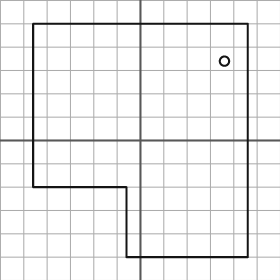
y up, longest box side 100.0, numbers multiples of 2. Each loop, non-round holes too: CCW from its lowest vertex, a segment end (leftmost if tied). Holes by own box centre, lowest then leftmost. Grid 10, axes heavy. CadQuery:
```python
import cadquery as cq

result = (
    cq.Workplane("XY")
    .moveTo(-6.0, -50.0)
    .lineTo(46.0, -50.0)
    .lineTo(46.0, 50.0)
    .lineTo(-46.0, 50.0)
    .lineTo(-46.0, -20.0)
    .lineTo(-6.0, -20.0)
    .close()
    .moveTo(36.0, 34.0)
    .circle(2.0)
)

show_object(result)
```